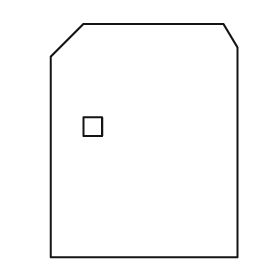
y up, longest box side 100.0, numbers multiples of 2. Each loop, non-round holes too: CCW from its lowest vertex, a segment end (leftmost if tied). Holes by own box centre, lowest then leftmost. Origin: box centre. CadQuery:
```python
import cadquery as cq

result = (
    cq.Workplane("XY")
    .moveTo(-40.0, -50.0)
    .lineTo(40.0, -50.0)
    .lineTo(40.0, 40.0)
    .lineTo(34.0, 50.0)
    .lineTo(-26.0, 50.0)
    .lineTo(-40.0, 36.0)
    .close()
    .moveTo(-26.0, 2.0)
    .lineTo(-18.0, 2.0)
    .lineTo(-18.0, 10.0)
    .lineTo(-26.0, 10.0)
    .close()
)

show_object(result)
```